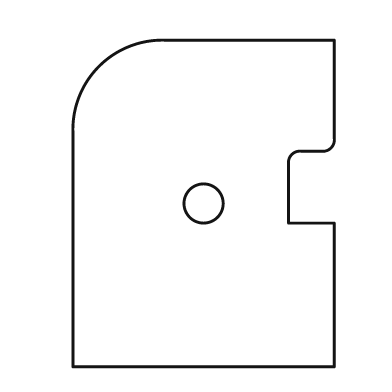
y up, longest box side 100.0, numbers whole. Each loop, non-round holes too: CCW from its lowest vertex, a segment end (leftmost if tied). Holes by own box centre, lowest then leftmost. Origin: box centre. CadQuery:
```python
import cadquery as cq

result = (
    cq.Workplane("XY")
    .moveTo(-40.0, -50.0)
    .lineTo(40.0, -50.0)
    .lineTo(40.0, -6.0)
    .lineTo(26.0, -6.0)
    .lineTo(26.0, 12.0)
    .threePointArc((27.0, 15.0), (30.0, 16.0))
    .lineTo(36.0, 16.0)
    .threePointArc((39.0, 17.0), (40.0, 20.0))
    .lineTo(40.0, 50.0)
    .lineTo(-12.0, 50.0)
    .threePointArc((-32.0, 42.0), (-40.0, 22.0))
    .close()
    .moveTo(0.0, 0.0)
    .circle(6.0)
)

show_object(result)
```